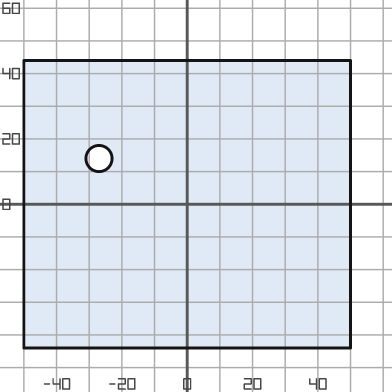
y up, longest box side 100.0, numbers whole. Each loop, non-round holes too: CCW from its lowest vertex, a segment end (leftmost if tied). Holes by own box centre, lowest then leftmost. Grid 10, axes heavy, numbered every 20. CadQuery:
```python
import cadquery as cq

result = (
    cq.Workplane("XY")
    .moveTo(-50.0, -44.0)
    .lineTo(50.0, -44.0)
    .lineTo(50.0, 44.0)
    .lineTo(-50.0, 44.0)
    .close()
    .moveTo(-27.0, 14.0)
    .circle(4.0)
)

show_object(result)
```